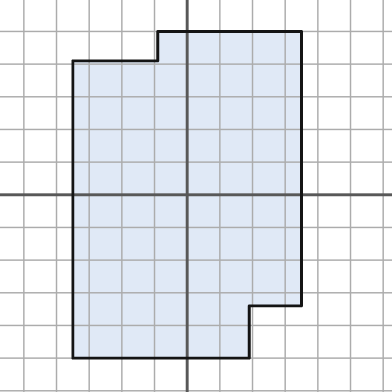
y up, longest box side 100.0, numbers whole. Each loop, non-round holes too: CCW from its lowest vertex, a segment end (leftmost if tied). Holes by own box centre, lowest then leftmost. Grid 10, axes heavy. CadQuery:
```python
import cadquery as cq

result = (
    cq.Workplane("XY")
    .moveTo(-35.0, -50.0)
    .lineTo(19.0, -50.0)
    .lineTo(19.0, -34.0)
    .lineTo(35.0, -34.0)
    .lineTo(35.0, 50.0)
    .lineTo(-9.0, 50.0)
    .lineTo(-9.0, 41.0)
    .lineTo(-35.0, 41.0)
    .close()
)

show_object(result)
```